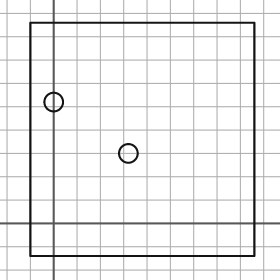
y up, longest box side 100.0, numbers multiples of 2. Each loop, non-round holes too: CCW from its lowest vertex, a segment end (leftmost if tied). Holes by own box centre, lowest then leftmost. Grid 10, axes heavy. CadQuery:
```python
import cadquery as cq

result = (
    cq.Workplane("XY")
    .moveTo(-10.0, -14.0)
    .lineTo(86.0, -14.0)
    .lineTo(86.0, 86.0)
    .lineTo(-10.0, 86.0)
    .close()
    .moveTo(32.0, 30.0)
    .circle(4.0)
    .moveTo(0.0, 52.0)
    .circle(4.0)
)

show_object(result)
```